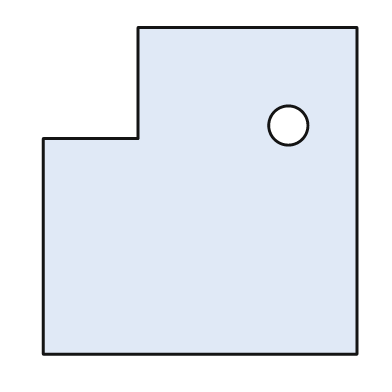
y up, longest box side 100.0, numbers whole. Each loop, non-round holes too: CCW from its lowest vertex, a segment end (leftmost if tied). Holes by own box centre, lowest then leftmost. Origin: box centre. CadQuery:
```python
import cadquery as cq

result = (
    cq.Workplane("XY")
    .moveTo(-48.0, -50.0)
    .lineTo(48.0, -50.0)
    .lineTo(48.0, 50.0)
    .lineTo(-19.0, 50.0)
    .lineTo(-19.0, 16.0)
    .lineTo(-48.0, 16.0)
    .close()
    .moveTo(27.0, 20.0)
    .circle(6.0)
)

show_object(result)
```